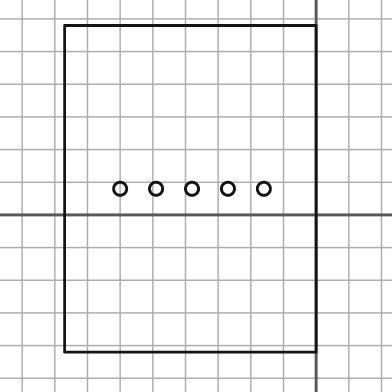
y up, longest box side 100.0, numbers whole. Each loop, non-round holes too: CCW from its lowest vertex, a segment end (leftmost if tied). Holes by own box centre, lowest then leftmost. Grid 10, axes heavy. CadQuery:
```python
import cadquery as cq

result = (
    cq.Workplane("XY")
    .moveTo(-77.0, -42.0)
    .lineTo(0.0, -42.0)
    .lineTo(0.0, 58.0)
    .lineTo(-77.0, 58.0)
    .close()
    .moveTo(-60.0, 8.0)
    .circle(2.0)
    .moveTo(-49.0, 8.0)
    .circle(2.0)
    .moveTo(-38.0, 8.0)
    .circle(2.0)
    .moveTo(-27.0, 8.0)
    .circle(2.0)
    .moveTo(-16.0, 8.0)
    .circle(2.0)
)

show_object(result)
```